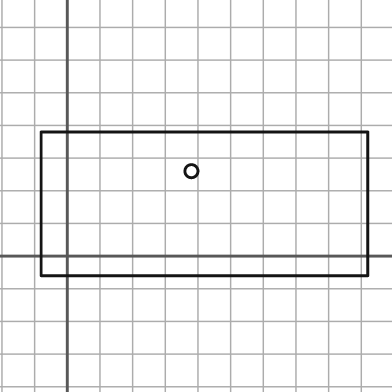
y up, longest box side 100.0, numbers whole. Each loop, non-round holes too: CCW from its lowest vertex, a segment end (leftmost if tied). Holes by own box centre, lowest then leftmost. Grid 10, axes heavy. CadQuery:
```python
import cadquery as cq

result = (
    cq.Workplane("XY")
    .moveTo(-8.0, -6.0)
    .lineTo(92.0, -6.0)
    .lineTo(92.0, 38.0)
    .lineTo(-8.0, 38.0)
    .close()
    .moveTo(38.0, 26.0)
    .circle(2.0)
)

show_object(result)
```